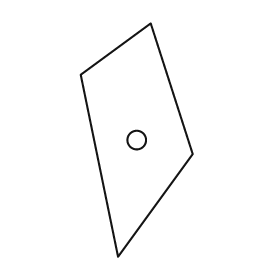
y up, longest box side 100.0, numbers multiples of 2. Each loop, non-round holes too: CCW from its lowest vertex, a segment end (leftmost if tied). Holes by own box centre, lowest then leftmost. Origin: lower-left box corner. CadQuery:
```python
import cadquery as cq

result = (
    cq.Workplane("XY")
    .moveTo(16.0, 0.0)
    .lineTo(48.0, 44.0)
    .lineTo(30.0, 100.0)
    .lineTo(0.0, 78.0)
    .close()
    .moveTo(24.0, 50.0)
    .circle(4.0)
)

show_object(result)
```